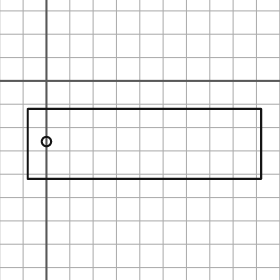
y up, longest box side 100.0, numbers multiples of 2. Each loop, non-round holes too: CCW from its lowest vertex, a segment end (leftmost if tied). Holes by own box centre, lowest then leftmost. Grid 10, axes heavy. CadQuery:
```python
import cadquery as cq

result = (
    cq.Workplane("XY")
    .moveTo(-8.0, -42.0)
    .lineTo(92.0, -42.0)
    .lineTo(92.0, -12.0)
    .lineTo(-8.0, -12.0)
    .close()
    .moveTo(0.0, -26.0)
    .circle(2.0)
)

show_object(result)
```